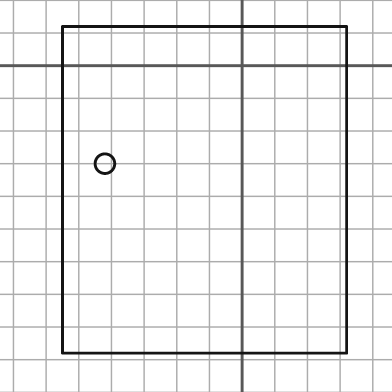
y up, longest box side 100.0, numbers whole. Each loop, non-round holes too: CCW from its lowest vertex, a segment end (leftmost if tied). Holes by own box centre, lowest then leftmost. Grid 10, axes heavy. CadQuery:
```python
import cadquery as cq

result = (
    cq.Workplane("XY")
    .moveTo(-55.0, -88.0)
    .lineTo(32.0, -88.0)
    .lineTo(32.0, 12.0)
    .lineTo(-55.0, 12.0)
    .close()
    .moveTo(-42.0, -30.0)
    .circle(3.0)
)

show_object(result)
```